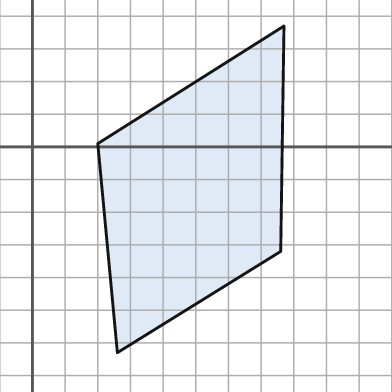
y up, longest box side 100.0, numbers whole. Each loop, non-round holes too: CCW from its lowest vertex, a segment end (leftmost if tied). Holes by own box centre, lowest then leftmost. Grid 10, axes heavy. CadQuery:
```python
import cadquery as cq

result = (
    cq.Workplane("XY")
    .moveTo(26.0, -63.0)
    .lineTo(76.0, -32.0)
    .lineTo(77.0, 37.0)
    .lineTo(20.0, 1.0)
    .close()
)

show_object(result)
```